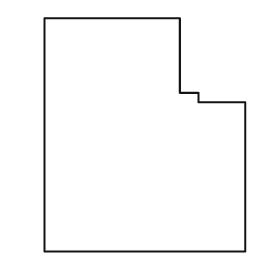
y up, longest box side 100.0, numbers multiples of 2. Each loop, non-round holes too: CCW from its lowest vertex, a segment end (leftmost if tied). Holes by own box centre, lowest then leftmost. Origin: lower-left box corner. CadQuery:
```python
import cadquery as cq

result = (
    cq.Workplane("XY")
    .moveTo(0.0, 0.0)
    .lineTo(86.0, 0.0)
    .lineTo(86.0, 64.0)
    .lineTo(66.0, 64.0)
    .lineTo(66.0, 68.0)
    .lineTo(58.0, 68.0)
    .lineTo(58.0, 100.0)
    .lineTo(0.0, 100.0)
    .close()
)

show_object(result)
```